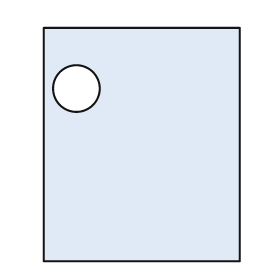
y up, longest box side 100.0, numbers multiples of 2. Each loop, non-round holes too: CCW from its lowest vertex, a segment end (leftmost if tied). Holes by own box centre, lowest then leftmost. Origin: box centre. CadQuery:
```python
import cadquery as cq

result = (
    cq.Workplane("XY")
    .moveTo(-42.0, -50.0)
    .lineTo(42.0, -50.0)
    .lineTo(42.0, 50.0)
    .lineTo(-42.0, 50.0)
    .close()
    .moveTo(-28.0, 24.0)
    .circle(10.0)
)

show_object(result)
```